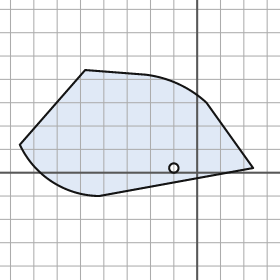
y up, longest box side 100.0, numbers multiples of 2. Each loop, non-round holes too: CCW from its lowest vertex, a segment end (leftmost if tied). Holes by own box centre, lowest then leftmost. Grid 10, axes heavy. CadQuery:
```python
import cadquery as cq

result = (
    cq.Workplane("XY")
    .moveTo(-42.0, -10.0)
    .lineTo(24.0, 2.0)
    .lineTo(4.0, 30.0)
    .threePointArc((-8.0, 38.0), (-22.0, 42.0))
    .lineTo(-48.0, 44.0)
    .lineTo(-76.0, 12.0)
    .threePointArc((-62.0, -4.0), (-42.0, -10.0))
    .close()
    .moveTo(-10.0, 2.0)
    .circle(2.0)
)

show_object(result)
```